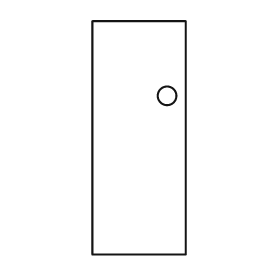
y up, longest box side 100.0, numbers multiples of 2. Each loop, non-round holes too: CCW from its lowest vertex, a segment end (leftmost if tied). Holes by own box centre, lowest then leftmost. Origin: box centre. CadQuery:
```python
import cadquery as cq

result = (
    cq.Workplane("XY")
    .moveTo(-20.0, -50.0)
    .lineTo(20.0, -50.0)
    .lineTo(20.0, 50.0)
    .lineTo(-20.0, 50.0)
    .close()
    .moveTo(12.0, 18.0)
    .circle(4.0)
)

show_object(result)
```